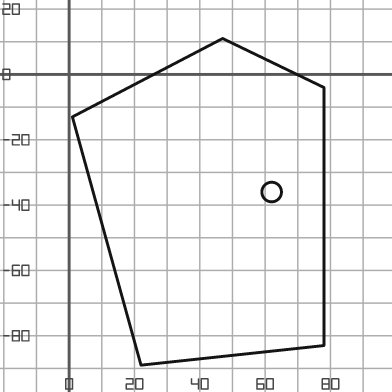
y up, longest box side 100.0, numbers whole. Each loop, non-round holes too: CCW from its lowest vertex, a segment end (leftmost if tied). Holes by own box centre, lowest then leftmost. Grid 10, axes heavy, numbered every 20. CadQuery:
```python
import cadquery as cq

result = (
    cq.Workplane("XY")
    .moveTo(22.0, -89.0)
    .lineTo(78.0, -83.0)
    .lineTo(78.0, -4.0)
    .lineTo(47.0, 11.0)
    .lineTo(1.0, -13.0)
    .close()
    .moveTo(62.0, -36.0)
    .circle(3.0)
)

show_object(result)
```